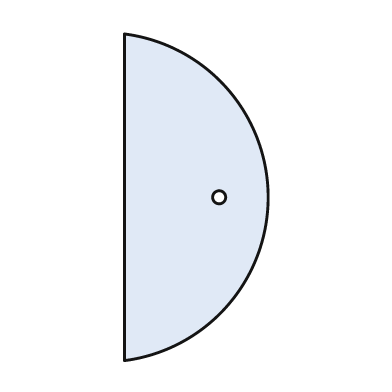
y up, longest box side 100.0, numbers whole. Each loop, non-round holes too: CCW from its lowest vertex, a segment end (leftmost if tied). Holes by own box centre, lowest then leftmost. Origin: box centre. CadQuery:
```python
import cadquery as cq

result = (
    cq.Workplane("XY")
    .moveTo(-22.0, -50.0)
    .threePointArc((22.0, 0.0), (-22.0, 50.0))
    .close()
    .moveTo(7.0, 0.0)
    .circle(2.0)
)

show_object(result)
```